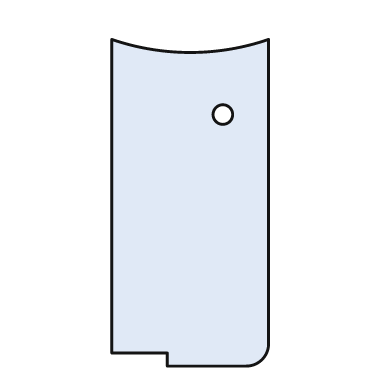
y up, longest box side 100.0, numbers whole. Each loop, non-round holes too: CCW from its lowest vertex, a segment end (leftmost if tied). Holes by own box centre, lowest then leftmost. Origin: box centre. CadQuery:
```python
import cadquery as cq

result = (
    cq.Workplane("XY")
    .moveTo(-7.0, -50.0)
    .lineTo(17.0, -50.0)
    .threePointArc((22.0, -48.0), (24.0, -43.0))
    .lineTo(24.0, 50.0)
    .threePointArc((0.0, 46.0), (-24.0, 50.0))
    .lineTo(-24.0, -46.0)
    .lineTo(-7.0, -46.0)
    .close()
    .moveTo(10.0, 27.0)
    .circle(3.0)
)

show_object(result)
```